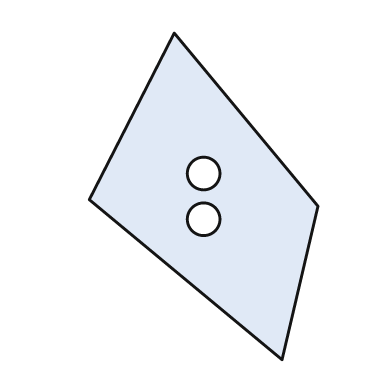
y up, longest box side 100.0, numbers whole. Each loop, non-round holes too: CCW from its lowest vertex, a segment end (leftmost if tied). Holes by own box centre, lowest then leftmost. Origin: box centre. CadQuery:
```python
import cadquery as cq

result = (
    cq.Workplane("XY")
    .moveTo(24.0, -50.0)
    .lineTo(35.0, -3.0)
    .lineTo(-9.0, 50.0)
    .lineTo(-35.0, -1.0)
    .close()
    .moveTo(0.0, -7.0)
    .circle(5.0)
    .moveTo(0.0, 7.0)
    .circle(5.0)
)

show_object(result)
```